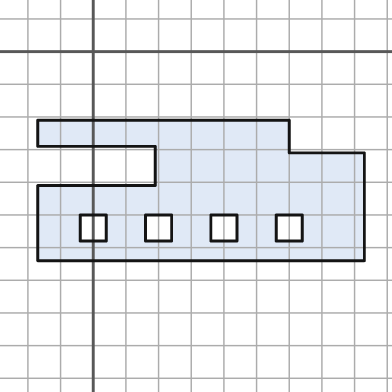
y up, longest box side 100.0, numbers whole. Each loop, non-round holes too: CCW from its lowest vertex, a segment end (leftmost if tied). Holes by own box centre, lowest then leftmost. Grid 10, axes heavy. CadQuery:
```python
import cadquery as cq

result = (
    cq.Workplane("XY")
    .moveTo(-17.0, -64.0)
    .lineTo(83.0, -64.0)
    .lineTo(83.0, -31.0)
    .lineTo(60.0, -31.0)
    .lineTo(60.0, -21.0)
    .lineTo(-17.0, -21.0)
    .lineTo(-17.0, -29.0)
    .lineTo(19.0, -29.0)
    .lineTo(19.0, -41.0)
    .lineTo(-17.0, -41.0)
    .close()
    .moveTo(-4.0, -58.0)
    .lineTo(4.0, -58.0)
    .lineTo(4.0, -50.0)
    .lineTo(-4.0, -50.0)
    .close()
    .moveTo(16.0, -58.0)
    .lineTo(24.0, -58.0)
    .lineTo(24.0, -50.0)
    .lineTo(16.0, -50.0)
    .close()
    .moveTo(36.0, -58.0)
    .lineTo(44.0, -58.0)
    .lineTo(44.0, -50.0)
    .lineTo(36.0, -50.0)
    .close()
    .moveTo(56.0, -58.0)
    .lineTo(64.0, -58.0)
    .lineTo(64.0, -50.0)
    .lineTo(56.0, -50.0)
    .close()
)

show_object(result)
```